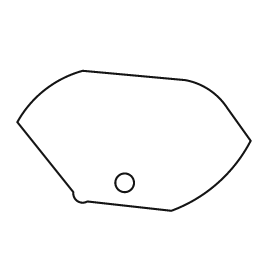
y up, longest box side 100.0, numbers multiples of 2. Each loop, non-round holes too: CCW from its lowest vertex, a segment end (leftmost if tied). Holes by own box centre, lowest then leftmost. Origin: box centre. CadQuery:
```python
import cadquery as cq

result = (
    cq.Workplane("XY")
    .moveTo(16.0, -30.0)
    .threePointArc((36.0, -18.0), (50.0, 0.0))
    .lineTo(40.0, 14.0)
    .threePointArc((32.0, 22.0), (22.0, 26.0))
    .lineTo(-22.0, 30.0)
    .threePointArc((-38.0, 22.0), (-50.0, 8.0))
    .lineTo(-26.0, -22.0)
    .threePointArc((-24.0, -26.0), (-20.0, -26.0))
    .close()
    .moveTo(-4.0, -18.0)
    .circle(4.0)
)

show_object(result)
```